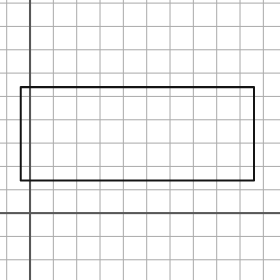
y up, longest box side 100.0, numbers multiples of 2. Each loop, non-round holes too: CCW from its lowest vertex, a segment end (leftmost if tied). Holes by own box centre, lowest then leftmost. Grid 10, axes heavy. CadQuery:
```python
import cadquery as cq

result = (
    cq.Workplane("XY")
    .moveTo(-4.0, 14.0)
    .lineTo(96.0, 14.0)
    .lineTo(96.0, 54.0)
    .lineTo(-4.0, 54.0)
    .close()
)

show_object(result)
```